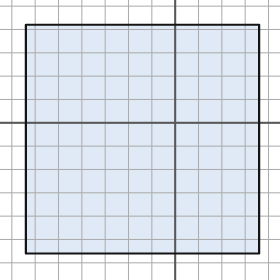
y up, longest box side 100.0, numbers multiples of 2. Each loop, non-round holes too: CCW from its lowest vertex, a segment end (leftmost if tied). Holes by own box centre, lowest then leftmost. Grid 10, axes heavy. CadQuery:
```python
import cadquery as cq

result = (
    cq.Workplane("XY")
    .moveTo(-64.0, -56.0)
    .lineTo(36.0, -56.0)
    .lineTo(36.0, 42.0)
    .lineTo(-64.0, 42.0)
    .close()
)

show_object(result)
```